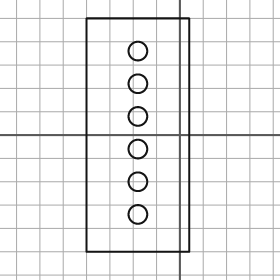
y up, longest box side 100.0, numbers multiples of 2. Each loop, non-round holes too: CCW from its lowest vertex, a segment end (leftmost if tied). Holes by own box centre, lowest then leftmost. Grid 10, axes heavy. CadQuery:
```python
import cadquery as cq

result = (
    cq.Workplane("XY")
    .moveTo(-40.0, -50.0)
    .lineTo(4.0, -50.0)
    .lineTo(4.0, 50.0)
    .lineTo(-40.0, 50.0)
    .close()
    .moveTo(-18.0, -34.0)
    .circle(4.0)
    .moveTo(-18.0, -20.0)
    .circle(4.0)
    .moveTo(-18.0, -6.0)
    .circle(4.0)
    .moveTo(-18.0, 8.0)
    .circle(4.0)
    .moveTo(-18.0, 22.0)
    .circle(4.0)
    .moveTo(-18.0, 36.0)
    .circle(4.0)
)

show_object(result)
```